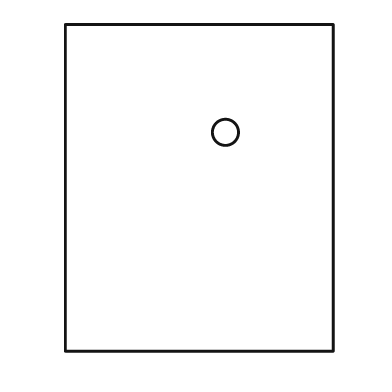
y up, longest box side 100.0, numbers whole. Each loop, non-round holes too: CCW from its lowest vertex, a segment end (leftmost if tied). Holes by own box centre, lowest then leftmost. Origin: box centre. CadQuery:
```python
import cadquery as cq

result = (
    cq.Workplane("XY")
    .moveTo(-41.0, -50.0)
    .lineTo(41.0, -50.0)
    .lineTo(41.0, 50.0)
    .lineTo(-41.0, 50.0)
    .close()
    .moveTo(8.0, 17.0)
    .circle(4.0)
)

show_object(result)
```